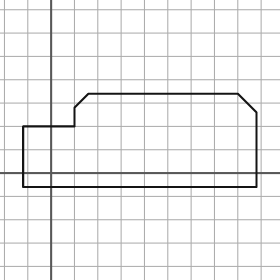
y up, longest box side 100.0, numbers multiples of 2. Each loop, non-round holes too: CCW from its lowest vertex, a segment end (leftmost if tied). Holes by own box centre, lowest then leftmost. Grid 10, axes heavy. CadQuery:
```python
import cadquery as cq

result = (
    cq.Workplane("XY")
    .moveTo(-12.0, -6.0)
    .lineTo(88.0, -6.0)
    .lineTo(88.0, 26.0)
    .lineTo(80.0, 34.0)
    .lineTo(16.0, 34.0)
    .lineTo(10.0, 28.0)
    .lineTo(10.0, 20.0)
    .lineTo(-12.0, 20.0)
    .close()
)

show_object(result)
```